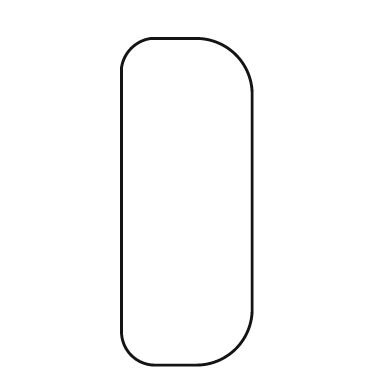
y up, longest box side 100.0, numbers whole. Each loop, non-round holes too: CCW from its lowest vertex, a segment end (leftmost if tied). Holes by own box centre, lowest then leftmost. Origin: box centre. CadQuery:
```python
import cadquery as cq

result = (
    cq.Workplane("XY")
    .moveTo(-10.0, -50.0)
    .lineTo(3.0, -50.0)
    .threePointArc((15.0, -45.0), (20.0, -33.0))
    .lineTo(20.0, 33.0)
    .threePointArc((15.0, 45.0), (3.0, 50.0))
    .lineTo(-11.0, 50.0)
    .threePointArc((-17.0, 47.0), (-20.0, 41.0))
    .lineTo(-20.0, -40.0)
    .threePointArc((-17.0, -47.0), (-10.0, -50.0))
    .close()
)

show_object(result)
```